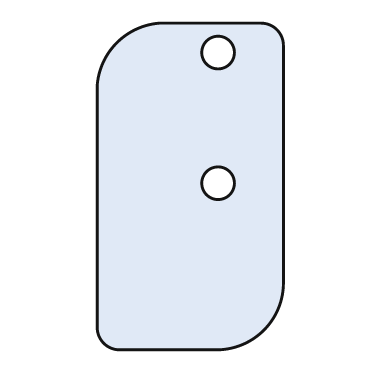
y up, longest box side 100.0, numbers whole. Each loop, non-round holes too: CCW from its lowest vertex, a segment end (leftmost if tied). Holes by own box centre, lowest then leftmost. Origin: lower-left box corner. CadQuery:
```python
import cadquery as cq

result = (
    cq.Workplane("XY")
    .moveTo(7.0, 0.0)
    .lineTo(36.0, 0.0)
    .threePointArc((51.0, 6.0), (57.0, 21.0))
    .lineTo(57.0, 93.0)
    .threePointArc((55.0, 98.0), (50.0, 100.0))
    .lineTo(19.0, 100.0)
    .threePointArc((6.0, 94.0), (0.0, 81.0))
    .lineTo(0.0, 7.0)
    .threePointArc((2.0, 2.0), (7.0, 0.0))
    .close()
    .moveTo(37.0, 51.0)
    .circle(5.0)
    .moveTo(37.0, 91.0)
    .circle(5.0)
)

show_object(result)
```